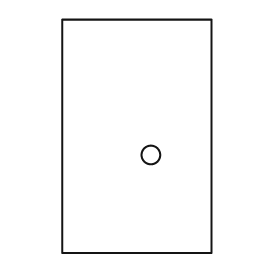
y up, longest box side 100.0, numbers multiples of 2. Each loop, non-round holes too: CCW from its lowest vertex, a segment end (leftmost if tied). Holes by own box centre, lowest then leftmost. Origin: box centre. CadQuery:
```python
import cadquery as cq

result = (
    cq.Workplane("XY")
    .moveTo(-32.0, -50.0)
    .lineTo(32.0, -50.0)
    .lineTo(32.0, 50.0)
    .lineTo(-32.0, 50.0)
    .close()
    .moveTo(6.0, -8.0)
    .circle(4.0)
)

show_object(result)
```